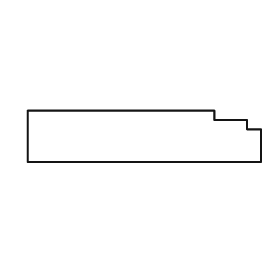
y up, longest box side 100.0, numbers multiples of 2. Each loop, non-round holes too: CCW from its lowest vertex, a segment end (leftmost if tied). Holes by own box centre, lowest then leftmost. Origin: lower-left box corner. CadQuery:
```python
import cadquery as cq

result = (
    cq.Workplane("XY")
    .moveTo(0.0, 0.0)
    .lineTo(100.0, 0.0)
    .lineTo(100.0, 14.0)
    .lineTo(94.0, 14.0)
    .lineTo(94.0, 18.0)
    .lineTo(80.0, 18.0)
    .lineTo(80.0, 22.0)
    .lineTo(0.0, 22.0)
    .close()
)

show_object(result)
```